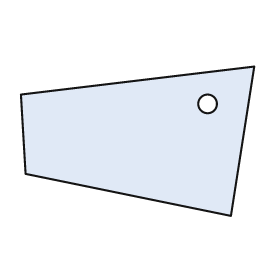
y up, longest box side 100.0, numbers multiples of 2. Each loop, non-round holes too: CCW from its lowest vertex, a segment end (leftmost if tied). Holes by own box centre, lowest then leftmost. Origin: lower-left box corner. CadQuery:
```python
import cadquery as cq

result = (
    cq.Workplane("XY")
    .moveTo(90.0, 0.0)
    .lineTo(100.0, 64.0)
    .lineTo(0.0, 52.0)
    .lineTo(2.0, 18.0)
    .close()
    .moveTo(80.0, 48.0)
    .circle(4.0)
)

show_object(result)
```